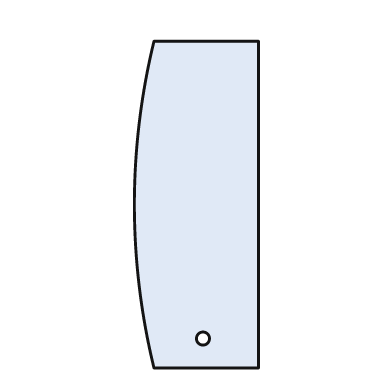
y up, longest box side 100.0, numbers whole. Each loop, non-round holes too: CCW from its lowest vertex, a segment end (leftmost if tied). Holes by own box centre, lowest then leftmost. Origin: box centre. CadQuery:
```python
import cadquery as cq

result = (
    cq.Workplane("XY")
    .moveTo(-13.0, -50.0)
    .lineTo(19.0, -50.0)
    .lineTo(19.0, 50.0)
    .lineTo(-13.0, 50.0)
    .threePointArc((-19.0, 0.0), (-13.0, -50.0))
    .close()
    .moveTo(2.0, -41.0)
    .circle(2.0)
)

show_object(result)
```